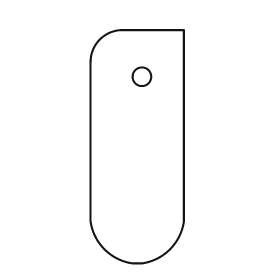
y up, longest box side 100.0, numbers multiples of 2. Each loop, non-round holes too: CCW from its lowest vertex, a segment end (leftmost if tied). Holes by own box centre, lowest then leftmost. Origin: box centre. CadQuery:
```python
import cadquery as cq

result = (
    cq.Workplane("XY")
    .moveTo(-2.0, -50.0)
    .lineTo(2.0, -50.0)
    .threePointArc((14.0, -44.0), (20.0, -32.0))
    .lineTo(20.0, 50.0)
    .lineTo(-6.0, 50.0)
    .threePointArc((-16.0, 46.0), (-20.0, 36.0))
    .lineTo(-20.0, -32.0)
    .threePointArc((-14.0, -44.0), (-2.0, -50.0))
    .close()
    .moveTo(2.0, 30.0)
    .circle(4.0)
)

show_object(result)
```